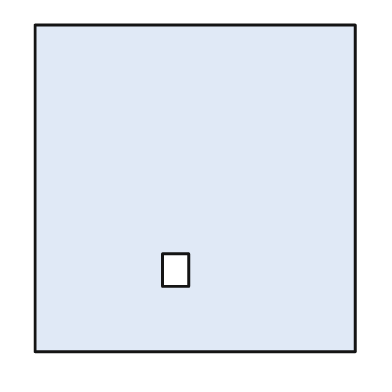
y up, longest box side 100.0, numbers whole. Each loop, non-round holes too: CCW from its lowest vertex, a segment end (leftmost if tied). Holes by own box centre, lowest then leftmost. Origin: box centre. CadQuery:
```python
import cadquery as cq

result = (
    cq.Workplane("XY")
    .moveTo(-49.0, -50.0)
    .lineTo(49.0, -50.0)
    .lineTo(49.0, 50.0)
    .lineTo(-49.0, 50.0)
    .close()
    .moveTo(-10.0, -30.0)
    .lineTo(-2.0, -30.0)
    .lineTo(-2.0, -20.0)
    .lineTo(-10.0, -20.0)
    .close()
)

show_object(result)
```